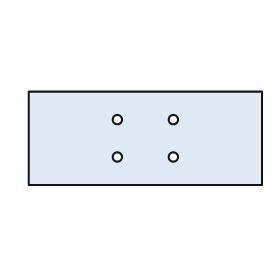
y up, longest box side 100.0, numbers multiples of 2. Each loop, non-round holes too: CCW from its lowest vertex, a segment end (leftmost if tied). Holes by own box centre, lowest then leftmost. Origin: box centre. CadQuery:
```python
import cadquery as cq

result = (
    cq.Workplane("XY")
    .moveTo(-50.0, -20.0)
    .lineTo(50.0, -20.0)
    .lineTo(50.0, 20.0)
    .lineTo(-50.0, 20.0)
    .close()
    .moveTo(-12.0, -8.0)
    .circle(2.0)
    .moveTo(12.0, -8.0)
    .circle(2.0)
    .moveTo(-12.0, 8.0)
    .circle(2.0)
    .moveTo(12.0, 8.0)
    .circle(2.0)
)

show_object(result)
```